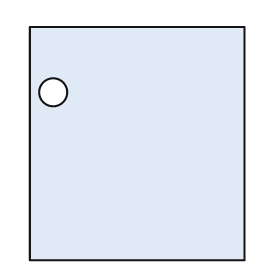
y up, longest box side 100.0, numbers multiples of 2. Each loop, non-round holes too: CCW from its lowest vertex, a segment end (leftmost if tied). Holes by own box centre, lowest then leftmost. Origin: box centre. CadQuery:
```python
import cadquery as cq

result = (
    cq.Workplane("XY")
    .moveTo(-46.0, -50.0)
    .lineTo(46.0, -50.0)
    .lineTo(46.0, 50.0)
    .lineTo(-46.0, 50.0)
    .close()
    .moveTo(-36.0, 22.0)
    .circle(6.0)
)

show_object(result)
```